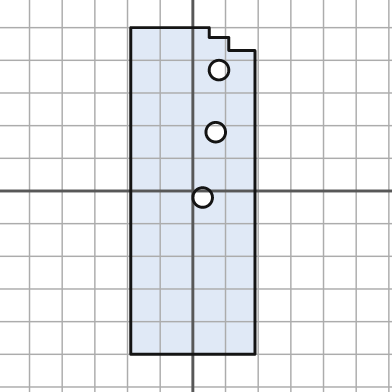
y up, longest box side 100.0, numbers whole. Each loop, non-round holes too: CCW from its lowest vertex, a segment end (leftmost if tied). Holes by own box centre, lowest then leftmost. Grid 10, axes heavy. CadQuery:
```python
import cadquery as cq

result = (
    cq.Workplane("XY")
    .moveTo(-19.0, -50.0)
    .lineTo(19.0, -50.0)
    .lineTo(19.0, 43.0)
    .lineTo(11.0, 43.0)
    .lineTo(11.0, 47.0)
    .lineTo(5.0, 47.0)
    .lineTo(5.0, 50.0)
    .lineTo(-19.0, 50.0)
    .close()
    .moveTo(3.0, -2.0)
    .circle(3.0)
    .moveTo(7.0, 18.0)
    .circle(3.0)
    .moveTo(8.0, 37.0)
    .circle(3.0)
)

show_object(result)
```